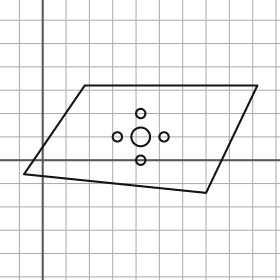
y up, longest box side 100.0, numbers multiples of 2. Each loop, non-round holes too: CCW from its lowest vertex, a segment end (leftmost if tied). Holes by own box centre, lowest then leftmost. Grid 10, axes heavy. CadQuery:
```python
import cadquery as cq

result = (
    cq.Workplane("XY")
    .moveTo(70.0, -14.0)
    .lineTo(92.0, 32.0)
    .lineTo(18.0, 32.0)
    .lineTo(-8.0, -6.0)
    .close()
    .moveTo(42.0, 0.0)
    .circle(2.0)
    .moveTo(32.0, 10.0)
    .circle(2.0)
    .moveTo(42.0, 10.0)
    .circle(4.0)
    .moveTo(52.0, 10.0)
    .circle(2.0)
    .moveTo(42.0, 20.0)
    .circle(2.0)
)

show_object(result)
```